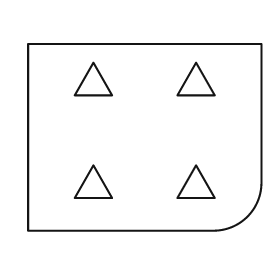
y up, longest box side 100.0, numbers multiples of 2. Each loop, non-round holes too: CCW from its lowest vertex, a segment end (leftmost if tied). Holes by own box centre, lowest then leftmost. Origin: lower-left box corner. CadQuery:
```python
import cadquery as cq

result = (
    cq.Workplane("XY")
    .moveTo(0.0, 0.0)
    .lineTo(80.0, 0.0)
    .threePointArc((94.0, 6.0), (100.0, 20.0))
    .lineTo(100.0, 80.0)
    .lineTo(0.0, 80.0)
    .close()
    .moveTo(20.0, 14.0)
    .lineTo(36.0, 14.0)
    .lineTo(28.0, 28.0)
    .close()
    .moveTo(64.0, 14.0)
    .lineTo(80.0, 14.0)
    .lineTo(72.0, 28.0)
    .close()
    .moveTo(20.0, 58.0)
    .lineTo(36.0, 58.0)
    .lineTo(28.0, 72.0)
    .close()
    .moveTo(64.0, 58.0)
    .lineTo(80.0, 58.0)
    .lineTo(72.0, 72.0)
    .close()
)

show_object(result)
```